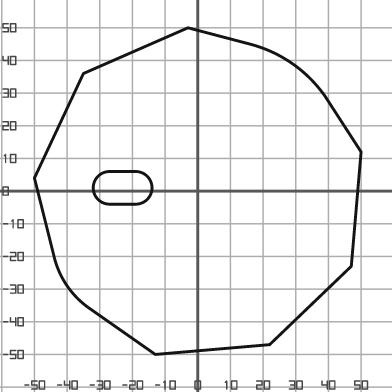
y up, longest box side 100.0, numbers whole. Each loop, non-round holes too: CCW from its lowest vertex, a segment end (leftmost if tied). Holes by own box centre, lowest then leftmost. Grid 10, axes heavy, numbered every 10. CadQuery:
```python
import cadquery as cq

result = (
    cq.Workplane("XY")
    .moveTo(-13.0, -50.0)
    .lineTo(22.0, -47.0)
    .lineTo(47.0, -23.0)
    .lineTo(50.0, 12.0)
    .lineTo(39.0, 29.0)
    .threePointArc((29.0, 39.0), (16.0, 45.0))
    .lineTo(-3.0, 50.0)
    .lineTo(-35.0, 36.0)
    .lineTo(-50.0, 4.0)
    .lineTo(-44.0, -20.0)
    .threePointArc((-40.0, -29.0), (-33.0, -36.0))
    .close()
    .moveTo(-27.0, -4.0)
    .lineTo(-19.0, -4.0)
    .threePointArc((-14.0, 1.0), (-19.0, 6.0))
    .lineTo(-27.0, 6.0)
    .threePointArc((-32.0, 1.0), (-27.0, -4.0))
    .close()
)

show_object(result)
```